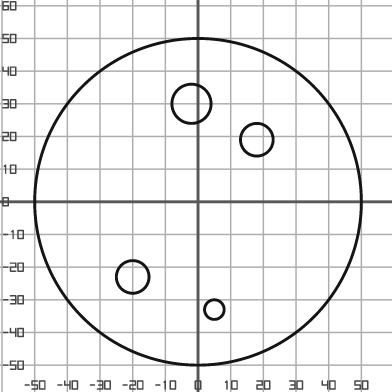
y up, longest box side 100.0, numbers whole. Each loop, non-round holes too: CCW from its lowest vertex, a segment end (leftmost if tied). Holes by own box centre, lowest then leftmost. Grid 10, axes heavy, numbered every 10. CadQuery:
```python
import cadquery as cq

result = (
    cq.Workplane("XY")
    .moveTo(0.0, 0.0)
    .circle(50.0)
    .moveTo(5.0, -33.0)
    .circle(3.0)
    .moveTo(-20.0, -23.0)
    .circle(5.0)
    .moveTo(18.0, 19.0)
    .circle(5.0)
    .moveTo(-2.0, 30.0)
    .circle(6.0)
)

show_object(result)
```